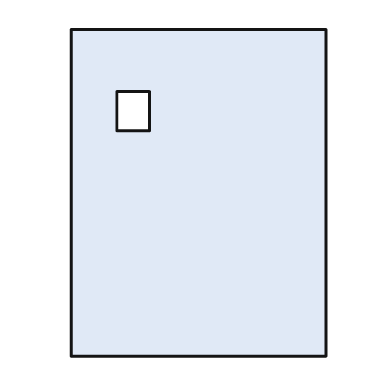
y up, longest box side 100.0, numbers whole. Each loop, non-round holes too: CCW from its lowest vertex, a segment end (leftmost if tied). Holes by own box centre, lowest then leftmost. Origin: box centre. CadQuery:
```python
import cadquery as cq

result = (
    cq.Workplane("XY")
    .moveTo(-39.0, -50.0)
    .lineTo(39.0, -50.0)
    .lineTo(39.0, 50.0)
    .lineTo(-39.0, 50.0)
    .close()
    .moveTo(-25.0, 19.0)
    .lineTo(-15.0, 19.0)
    .lineTo(-15.0, 31.0)
    .lineTo(-25.0, 31.0)
    .close()
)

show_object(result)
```